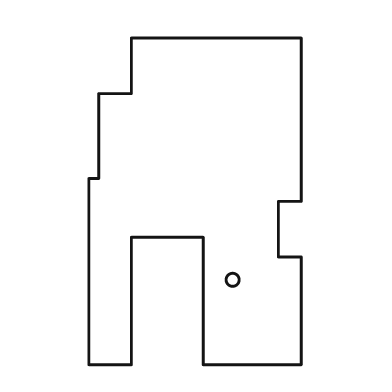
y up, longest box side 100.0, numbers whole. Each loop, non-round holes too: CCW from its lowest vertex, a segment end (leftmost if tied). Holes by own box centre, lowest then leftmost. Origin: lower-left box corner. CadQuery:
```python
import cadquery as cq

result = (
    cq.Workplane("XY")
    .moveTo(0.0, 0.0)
    .lineTo(13.0, 0.0)
    .lineTo(13.0, 39.0)
    .lineTo(35.0, 39.0)
    .lineTo(35.0, 0.0)
    .lineTo(65.0, 0.0)
    .lineTo(65.0, 33.0)
    .lineTo(58.0, 33.0)
    .lineTo(58.0, 50.0)
    .lineTo(65.0, 50.0)
    .lineTo(65.0, 100.0)
    .lineTo(13.0, 100.0)
    .lineTo(13.0, 83.0)
    .lineTo(3.0, 83.0)
    .lineTo(3.0, 57.0)
    .lineTo(0.0, 57.0)
    .close()
    .moveTo(44.0, 26.0)
    .circle(2.0)
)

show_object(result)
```